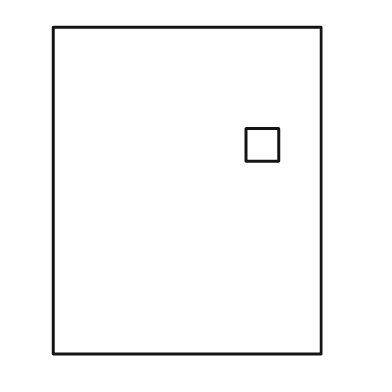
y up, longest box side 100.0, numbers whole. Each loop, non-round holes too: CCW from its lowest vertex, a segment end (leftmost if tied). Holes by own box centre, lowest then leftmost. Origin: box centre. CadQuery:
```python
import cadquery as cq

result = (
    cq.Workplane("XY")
    .moveTo(-41.0, -50.0)
    .lineTo(41.0, -50.0)
    .lineTo(41.0, 50.0)
    .lineTo(-41.0, 50.0)
    .close()
    .moveTo(18.0, 9.0)
    .lineTo(28.0, 9.0)
    .lineTo(28.0, 19.0)
    .lineTo(18.0, 19.0)
    .close()
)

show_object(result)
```